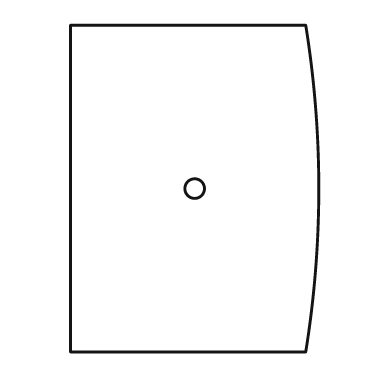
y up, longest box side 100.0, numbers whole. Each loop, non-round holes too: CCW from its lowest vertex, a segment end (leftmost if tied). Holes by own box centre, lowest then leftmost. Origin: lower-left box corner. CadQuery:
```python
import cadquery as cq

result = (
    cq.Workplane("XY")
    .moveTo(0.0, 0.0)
    .lineTo(72.0, 0.0)
    .threePointArc((76.0, 50.0), (72.0, 100.0))
    .lineTo(0.0, 100.0)
    .close()
    .moveTo(38.0, 50.0)
    .circle(3.0)
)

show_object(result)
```